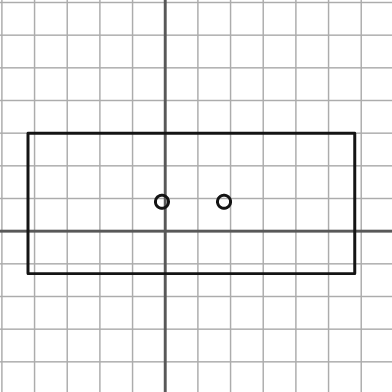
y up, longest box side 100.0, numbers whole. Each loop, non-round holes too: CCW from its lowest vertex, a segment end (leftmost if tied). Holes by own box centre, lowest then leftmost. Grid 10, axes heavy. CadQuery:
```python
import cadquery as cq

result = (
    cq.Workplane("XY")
    .moveTo(-42.0, -13.0)
    .lineTo(58.0, -13.0)
    .lineTo(58.0, 30.0)
    .lineTo(-42.0, 30.0)
    .close()
    .moveTo(-1.0, 9.0)
    .circle(2.0)
    .moveTo(18.0, 9.0)
    .circle(2.0)
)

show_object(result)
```